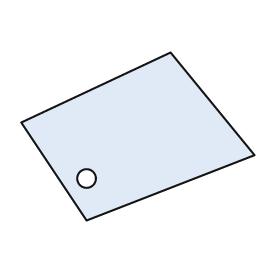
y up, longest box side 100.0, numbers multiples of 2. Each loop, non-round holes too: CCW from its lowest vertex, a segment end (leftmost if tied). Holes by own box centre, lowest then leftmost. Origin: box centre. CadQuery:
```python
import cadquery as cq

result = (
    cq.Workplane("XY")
    .moveTo(-22.0, -36.0)
    .lineTo(50.0, -8.0)
    .lineTo(14.0, 36.0)
    .lineTo(-50.0, 6.0)
    .close()
    .moveTo(-22.0, -18.0)
    .circle(4.0)
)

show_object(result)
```